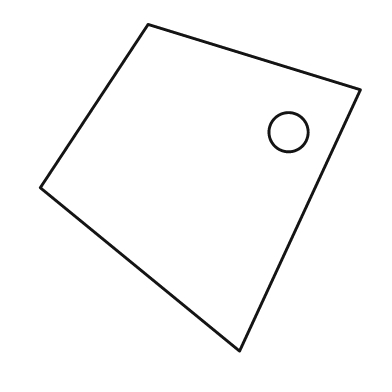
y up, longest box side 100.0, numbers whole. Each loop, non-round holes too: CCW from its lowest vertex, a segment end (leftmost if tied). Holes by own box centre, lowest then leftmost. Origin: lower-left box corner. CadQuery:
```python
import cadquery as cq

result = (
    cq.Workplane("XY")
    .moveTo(61.0, 0.0)
    .lineTo(98.0, 80.0)
    .lineTo(33.0, 100.0)
    .lineTo(0.0, 50.0)
    .close()
    .moveTo(76.0, 67.0)
    .circle(6.0)
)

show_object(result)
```